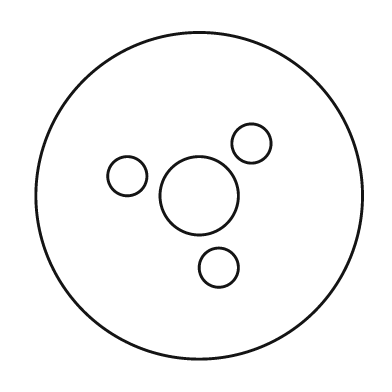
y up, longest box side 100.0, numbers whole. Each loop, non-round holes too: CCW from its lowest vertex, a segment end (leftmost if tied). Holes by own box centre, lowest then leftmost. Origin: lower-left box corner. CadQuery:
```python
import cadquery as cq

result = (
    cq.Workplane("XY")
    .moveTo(50.0, 50.0)
    .circle(50.0)
    .moveTo(56.0, 28.0)
    .circle(6.0)
    .moveTo(50.0, 50.0)
    .circle(12.0)
    .moveTo(28.0, 56.0)
    .circle(6.0)
    .moveTo(66.0, 66.0)
    .circle(6.0)
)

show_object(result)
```